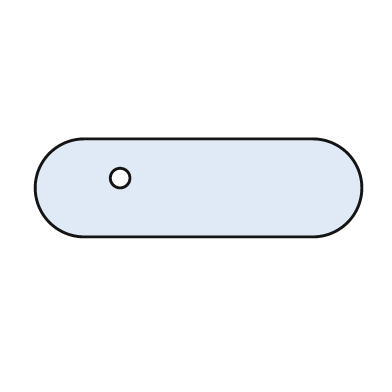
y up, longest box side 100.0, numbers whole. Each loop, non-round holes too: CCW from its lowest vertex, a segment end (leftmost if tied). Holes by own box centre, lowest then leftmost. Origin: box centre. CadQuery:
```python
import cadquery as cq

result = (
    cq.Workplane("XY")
    .moveTo(-35.0, -15.0)
    .lineTo(35.0, -15.0)
    .threePointArc((50.0, 0.0), (35.0, 15.0))
    .lineTo(-35.0, 15.0)
    .threePointArc((-50.0, 0.0), (-35.0, -15.0))
    .close()
    .moveTo(-24.0, 3.0)
    .circle(3.0)
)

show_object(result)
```